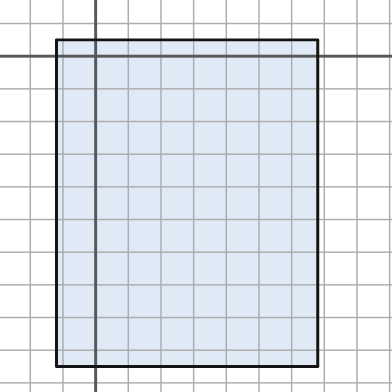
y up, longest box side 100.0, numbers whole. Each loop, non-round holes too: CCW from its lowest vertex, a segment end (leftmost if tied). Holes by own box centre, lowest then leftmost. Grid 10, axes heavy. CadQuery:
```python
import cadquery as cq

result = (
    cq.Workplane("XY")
    .moveTo(-12.0, -95.0)
    .lineTo(68.0, -95.0)
    .lineTo(68.0, 5.0)
    .lineTo(-12.0, 5.0)
    .close()
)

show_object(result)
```